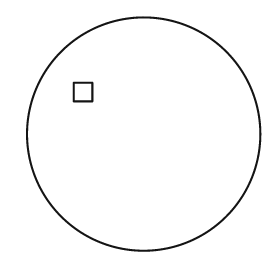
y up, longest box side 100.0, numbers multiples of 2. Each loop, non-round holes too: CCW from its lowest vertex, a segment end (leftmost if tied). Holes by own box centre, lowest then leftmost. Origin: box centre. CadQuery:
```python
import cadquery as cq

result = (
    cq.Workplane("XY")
    .moveTo(0.0, 0.0)
    .circle(50.0)
    .moveTo(-30.0, 14.0)
    .lineTo(-22.0, 14.0)
    .lineTo(-22.0, 22.0)
    .lineTo(-30.0, 22.0)
    .close()
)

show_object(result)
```